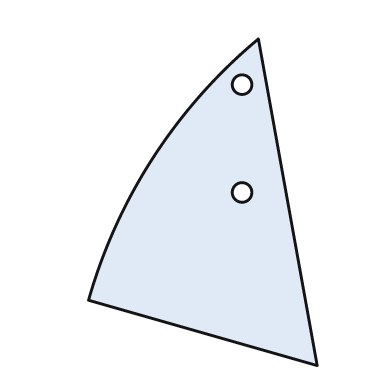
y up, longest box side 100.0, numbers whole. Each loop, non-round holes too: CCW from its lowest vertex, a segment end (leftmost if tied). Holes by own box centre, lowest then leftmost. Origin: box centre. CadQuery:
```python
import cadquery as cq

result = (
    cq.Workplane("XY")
    .moveTo(35.0, -50.0)
    .lineTo(17.0, 50.0)
    .threePointArc((-15.0, 14.0), (-35.0, -30.0))
    .close()
    .moveTo(12.0, 3.0)
    .circle(3.0)
    .moveTo(12.0, 36.0)
    .circle(3.0)
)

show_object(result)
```